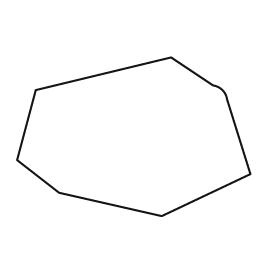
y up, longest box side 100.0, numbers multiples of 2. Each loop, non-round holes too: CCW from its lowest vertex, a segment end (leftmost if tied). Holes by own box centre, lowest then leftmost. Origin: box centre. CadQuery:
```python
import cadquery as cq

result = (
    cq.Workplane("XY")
    .moveTo(12.0, -34.0)
    .lineTo(50.0, -16.0)
    .lineTo(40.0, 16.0)
    .threePointArc((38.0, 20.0), (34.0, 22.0))
    .lineTo(16.0, 34.0)
    .lineTo(-42.0, 20.0)
    .lineTo(-50.0, -10.0)
    .lineTo(-32.0, -24.0)
    .close()
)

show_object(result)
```